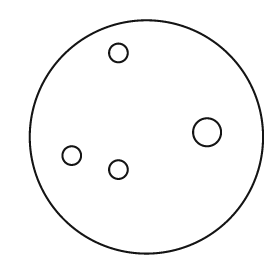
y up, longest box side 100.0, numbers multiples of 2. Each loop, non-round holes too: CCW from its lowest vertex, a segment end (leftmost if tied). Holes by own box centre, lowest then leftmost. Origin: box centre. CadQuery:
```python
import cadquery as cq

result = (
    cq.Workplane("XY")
    .moveTo(0.0, 0.0)
    .circle(50.0)
    .moveTo(-12.0, -14.0)
    .circle(4.0)
    .moveTo(-32.0, -8.0)
    .circle(4.0)
    .moveTo(26.0, 2.0)
    .circle(6.0)
    .moveTo(-12.0, 36.0)
    .circle(4.0)
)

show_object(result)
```